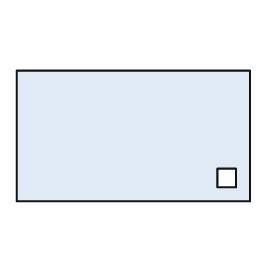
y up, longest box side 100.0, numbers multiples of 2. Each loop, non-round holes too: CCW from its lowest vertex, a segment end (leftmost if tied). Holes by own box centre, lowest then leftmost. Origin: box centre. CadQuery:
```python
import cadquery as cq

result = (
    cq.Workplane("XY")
    .moveTo(-50.0, -28.0)
    .lineTo(50.0, -28.0)
    .lineTo(50.0, 28.0)
    .lineTo(-50.0, 28.0)
    .close()
    .moveTo(36.0, -22.0)
    .lineTo(44.0, -22.0)
    .lineTo(44.0, -14.0)
    .lineTo(36.0, -14.0)
    .close()
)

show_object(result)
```